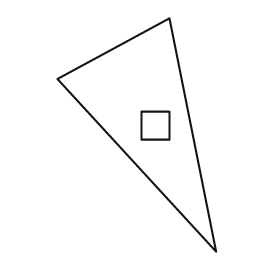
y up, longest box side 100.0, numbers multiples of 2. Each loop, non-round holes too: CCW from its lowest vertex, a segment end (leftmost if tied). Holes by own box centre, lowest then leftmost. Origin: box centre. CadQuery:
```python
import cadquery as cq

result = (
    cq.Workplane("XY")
    .moveTo(34.0, -50.0)
    .lineTo(14.0, 50.0)
    .lineTo(-34.0, 24.0)
    .close()
    .moveTo(2.0, -2.0)
    .lineTo(14.0, -2.0)
    .lineTo(14.0, 10.0)
    .lineTo(2.0, 10.0)
    .close()
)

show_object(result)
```